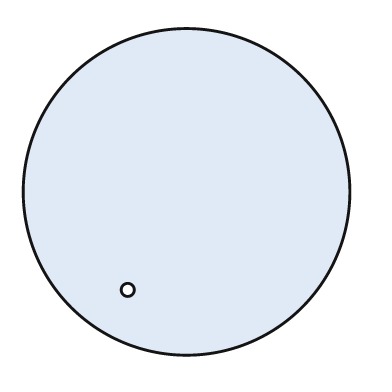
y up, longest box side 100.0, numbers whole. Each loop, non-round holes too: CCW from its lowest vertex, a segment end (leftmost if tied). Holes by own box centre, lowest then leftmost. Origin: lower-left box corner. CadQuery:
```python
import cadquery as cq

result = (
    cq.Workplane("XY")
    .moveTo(50.0, 50.0)
    .circle(50.0)
    .moveTo(32.0, 20.0)
    .circle(2.0)
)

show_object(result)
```